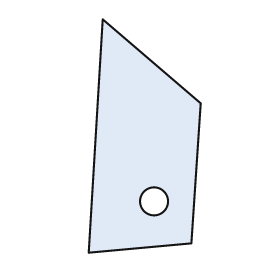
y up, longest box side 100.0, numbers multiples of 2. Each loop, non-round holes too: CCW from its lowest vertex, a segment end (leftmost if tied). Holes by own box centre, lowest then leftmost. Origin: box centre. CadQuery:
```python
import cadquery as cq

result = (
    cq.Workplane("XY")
    .moveTo(-24.0, -50.0)
    .lineTo(20.0, -46.0)
    .lineTo(24.0, 14.0)
    .lineTo(-18.0, 50.0)
    .close()
    .moveTo(4.0, -28.0)
    .circle(6.0)
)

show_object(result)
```